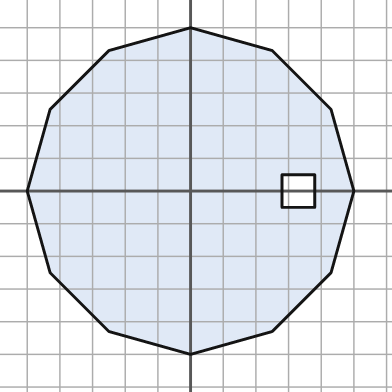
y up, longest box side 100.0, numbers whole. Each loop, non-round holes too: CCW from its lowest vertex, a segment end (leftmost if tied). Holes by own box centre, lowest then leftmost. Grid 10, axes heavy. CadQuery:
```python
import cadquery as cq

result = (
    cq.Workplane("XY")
    .moveTo(0.0, -50.0)
    .lineTo(25.0, -43.0)
    .lineTo(43.0, -25.0)
    .lineTo(50.0, 0.0)
    .lineTo(43.0, 25.0)
    .lineTo(25.0, 43.0)
    .lineTo(0.0, 50.0)
    .lineTo(-25.0, 43.0)
    .lineTo(-43.0, 25.0)
    .lineTo(-50.0, 0.0)
    .lineTo(-43.0, -25.0)
    .lineTo(-25.0, -43.0)
    .close()
    .moveTo(28.0, -5.0)
    .lineTo(38.0, -5.0)
    .lineTo(38.0, 5.0)
    .lineTo(28.0, 5.0)
    .close()
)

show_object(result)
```